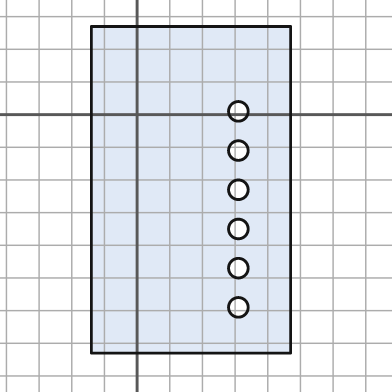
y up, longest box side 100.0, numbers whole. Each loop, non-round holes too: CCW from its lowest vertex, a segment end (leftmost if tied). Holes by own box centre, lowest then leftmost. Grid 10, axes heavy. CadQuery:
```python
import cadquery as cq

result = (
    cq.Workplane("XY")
    .moveTo(-14.0, -73.0)
    .lineTo(47.0, -73.0)
    .lineTo(47.0, 27.0)
    .lineTo(-14.0, 27.0)
    .close()
    .moveTo(31.0, -59.0)
    .circle(3.0)
    .moveTo(31.0, -47.0)
    .circle(3.0)
    .moveTo(31.0, -35.0)
    .circle(3.0)
    .moveTo(31.0, -23.0)
    .circle(3.0)
    .moveTo(31.0, -11.0)
    .circle(3.0)
    .moveTo(31.0, 1.0)
    .circle(3.0)
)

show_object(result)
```